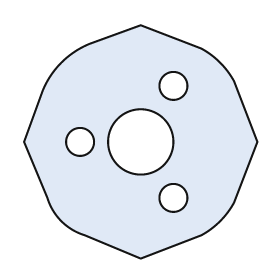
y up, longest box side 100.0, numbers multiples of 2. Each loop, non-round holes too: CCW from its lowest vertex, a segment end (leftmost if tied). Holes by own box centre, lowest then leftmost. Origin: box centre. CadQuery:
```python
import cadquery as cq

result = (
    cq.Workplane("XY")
    .moveTo(0.0, -50.0)
    .lineTo(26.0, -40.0)
    .threePointArc((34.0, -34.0), (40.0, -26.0))
    .lineTo(50.0, 0.0)
    .lineTo(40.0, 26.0)
    .threePointArc((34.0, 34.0), (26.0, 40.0))
    .lineTo(0.0, 50.0)
    .lineTo(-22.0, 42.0)
    .threePointArc((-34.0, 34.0), (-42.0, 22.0))
    .lineTo(-50.0, 0.0)
    .lineTo(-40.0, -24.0)
    .threePointArc((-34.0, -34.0), (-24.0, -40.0))
    .close()
    .moveTo(14.0, -24.0)
    .circle(6.0)
    .moveTo(-26.0, 0.0)
    .circle(6.0)
    .moveTo(0.0, 0.0)
    .circle(14.0)
    .moveTo(14.0, 24.0)
    .circle(6.0)
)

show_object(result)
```